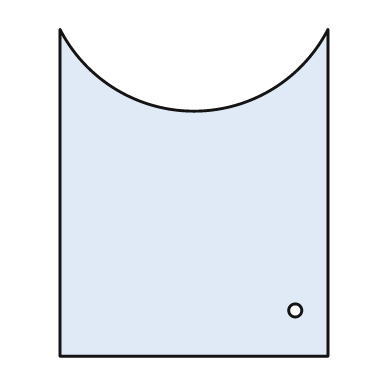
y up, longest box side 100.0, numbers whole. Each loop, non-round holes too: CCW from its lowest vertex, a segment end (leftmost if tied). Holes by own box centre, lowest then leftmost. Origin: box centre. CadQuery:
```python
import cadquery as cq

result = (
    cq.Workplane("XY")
    .moveTo(-41.0, -50.0)
    .lineTo(41.0, -50.0)
    .lineTo(41.0, 50.0)
    .threePointArc((0.0, 25.0), (-41.0, 50.0))
    .close()
    .moveTo(31.0, -36.0)
    .circle(2.0)
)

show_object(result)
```